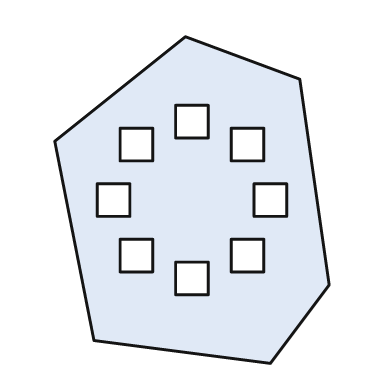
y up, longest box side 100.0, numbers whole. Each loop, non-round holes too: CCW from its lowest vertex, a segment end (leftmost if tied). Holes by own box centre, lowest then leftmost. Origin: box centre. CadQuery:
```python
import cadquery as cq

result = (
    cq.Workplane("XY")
    .moveTo(24.0, -50.0)
    .lineTo(42.0, -26.0)
    .lineTo(33.0, 37.0)
    .lineTo(-2.0, 50.0)
    .lineTo(-42.0, 18.0)
    .lineTo(-30.0, -43.0)
    .close()
    .moveTo(-5.0, -29.0)
    .lineTo(5.0, -29.0)
    .lineTo(5.0, -19.0)
    .lineTo(-5.0, -19.0)
    .close()
    .moveTo(-22.0, -22.0)
    .lineTo(-12.0, -22.0)
    .lineTo(-12.0, -12.0)
    .lineTo(-22.0, -12.0)
    .close()
    .moveTo(12.0, -22.0)
    .lineTo(22.0, -22.0)
    .lineTo(22.0, -12.0)
    .lineTo(12.0, -12.0)
    .close()
    .moveTo(-29.0, -5.0)
    .lineTo(-19.0, -5.0)
    .lineTo(-19.0, 5.0)
    .lineTo(-29.0, 5.0)
    .close()
    .moveTo(19.0, -5.0)
    .lineTo(29.0, -5.0)
    .lineTo(29.0, 5.0)
    .lineTo(19.0, 5.0)
    .close()
    .moveTo(-22.0, 12.0)
    .lineTo(-12.0, 12.0)
    .lineTo(-12.0, 22.0)
    .lineTo(-22.0, 22.0)
    .close()
    .moveTo(12.0, 12.0)
    .lineTo(22.0, 12.0)
    .lineTo(22.0, 22.0)
    .lineTo(12.0, 22.0)
    .close()
    .moveTo(-5.0, 19.0)
    .lineTo(5.0, 19.0)
    .lineTo(5.0, 29.0)
    .lineTo(-5.0, 29.0)
    .close()
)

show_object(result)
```